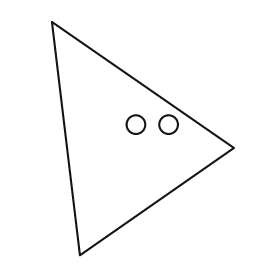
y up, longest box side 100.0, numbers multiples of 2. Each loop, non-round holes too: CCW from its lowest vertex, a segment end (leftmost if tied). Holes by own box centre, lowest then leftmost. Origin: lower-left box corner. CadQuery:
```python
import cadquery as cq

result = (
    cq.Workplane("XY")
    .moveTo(12.0, 0.0)
    .lineTo(78.0, 46.0)
    .lineTo(0.0, 100.0)
    .close()
    .moveTo(36.0, 56.0)
    .circle(4.0)
    .moveTo(50.0, 56.0)
    .circle(4.0)
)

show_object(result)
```